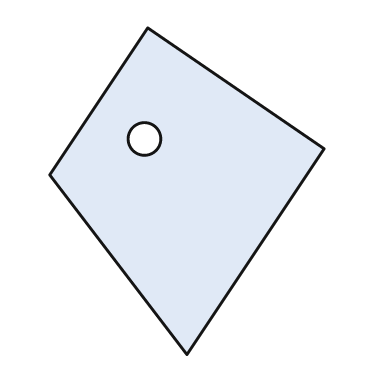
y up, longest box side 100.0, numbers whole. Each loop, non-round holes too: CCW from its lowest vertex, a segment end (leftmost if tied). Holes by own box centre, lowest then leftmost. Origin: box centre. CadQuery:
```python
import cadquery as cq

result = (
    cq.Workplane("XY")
    .moveTo(0.0, -50.0)
    .lineTo(42.0, 13.0)
    .lineTo(-12.0, 50.0)
    .lineTo(-42.0, 5.0)
    .close()
    .moveTo(-13.0, 16.0)
    .circle(5.0)
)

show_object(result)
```